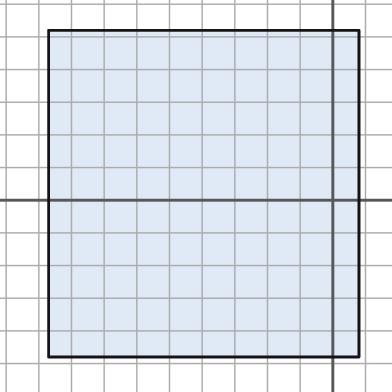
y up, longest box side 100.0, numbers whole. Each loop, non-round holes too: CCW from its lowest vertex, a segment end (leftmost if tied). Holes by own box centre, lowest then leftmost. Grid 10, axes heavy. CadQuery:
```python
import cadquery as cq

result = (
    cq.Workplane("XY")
    .moveTo(-87.0, -48.0)
    .lineTo(8.0, -48.0)
    .lineTo(8.0, 52.0)
    .lineTo(-87.0, 52.0)
    .close()
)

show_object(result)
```